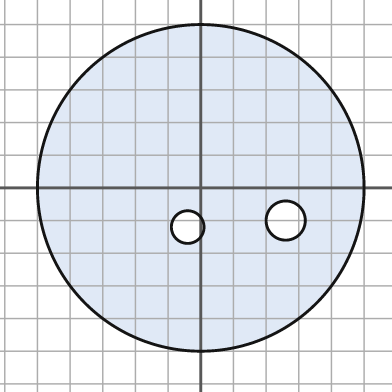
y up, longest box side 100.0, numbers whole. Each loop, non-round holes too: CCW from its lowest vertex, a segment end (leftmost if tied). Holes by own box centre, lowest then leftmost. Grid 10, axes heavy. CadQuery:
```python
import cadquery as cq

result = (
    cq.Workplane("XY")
    .moveTo(0.0, 0.0)
    .circle(50.0)
    .moveTo(-4.0, -12.0)
    .circle(5.0)
    .moveTo(26.0, -10.0)
    .circle(6.0)
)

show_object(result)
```